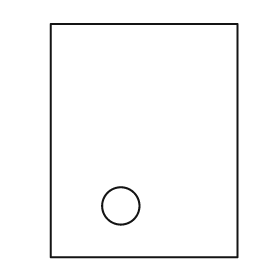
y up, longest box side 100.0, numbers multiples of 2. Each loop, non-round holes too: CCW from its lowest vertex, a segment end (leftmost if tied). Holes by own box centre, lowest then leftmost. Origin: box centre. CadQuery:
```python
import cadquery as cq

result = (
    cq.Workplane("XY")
    .moveTo(-40.0, -50.0)
    .lineTo(40.0, -50.0)
    .lineTo(40.0, 50.0)
    .lineTo(-40.0, 50.0)
    .close()
    .moveTo(-10.0, -28.0)
    .circle(8.0)
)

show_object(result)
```